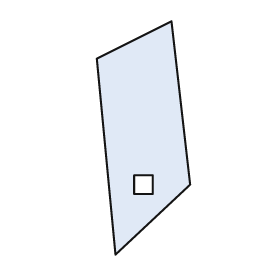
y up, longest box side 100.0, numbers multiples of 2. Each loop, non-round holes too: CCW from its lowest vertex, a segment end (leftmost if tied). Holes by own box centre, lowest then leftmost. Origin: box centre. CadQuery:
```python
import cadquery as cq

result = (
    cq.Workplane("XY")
    .moveTo(-12.0, -50.0)
    .lineTo(20.0, -20.0)
    .lineTo(12.0, 50.0)
    .lineTo(-20.0, 34.0)
    .close()
    .moveTo(-4.0, -24.0)
    .lineTo(4.0, -24.0)
    .lineTo(4.0, -16.0)
    .lineTo(-4.0, -16.0)
    .close()
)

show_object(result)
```